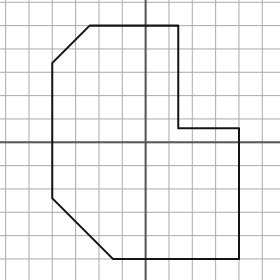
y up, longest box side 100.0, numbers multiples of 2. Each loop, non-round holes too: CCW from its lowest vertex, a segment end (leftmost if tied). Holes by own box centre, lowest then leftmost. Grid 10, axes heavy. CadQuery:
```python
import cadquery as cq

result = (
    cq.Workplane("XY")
    .moveTo(-14.0, -50.0)
    .lineTo(40.0, -50.0)
    .lineTo(40.0, 6.0)
    .lineTo(14.0, 6.0)
    .lineTo(14.0, 50.0)
    .lineTo(-24.0, 50.0)
    .lineTo(-40.0, 34.0)
    .lineTo(-40.0, -24.0)
    .close()
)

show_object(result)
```